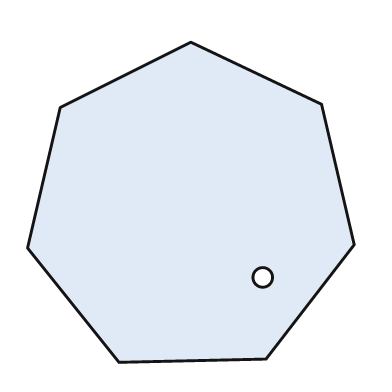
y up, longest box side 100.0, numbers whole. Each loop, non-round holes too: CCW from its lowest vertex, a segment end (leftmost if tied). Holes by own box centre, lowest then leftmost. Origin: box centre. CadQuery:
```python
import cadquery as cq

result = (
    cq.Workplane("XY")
    .moveTo(-22.0, -49.0)
    .lineTo(23.0, -48.0)
    .lineTo(50.0, -13.0)
    .lineTo(40.0, 30.0)
    .lineTo(0.0, 49.0)
    .lineTo(-40.0, 29.0)
    .lineTo(-50.0, -14.0)
    .close()
    .moveTo(22.0, -23.0)
    .circle(3.0)
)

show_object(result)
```